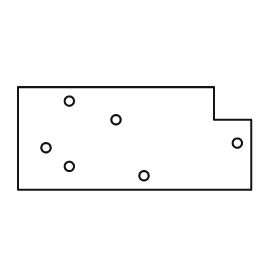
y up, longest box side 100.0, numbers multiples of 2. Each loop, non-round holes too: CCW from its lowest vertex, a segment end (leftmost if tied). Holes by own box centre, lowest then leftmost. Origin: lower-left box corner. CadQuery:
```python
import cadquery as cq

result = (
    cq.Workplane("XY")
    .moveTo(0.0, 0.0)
    .lineTo(100.0, 0.0)
    .lineTo(100.0, 30.0)
    .lineTo(84.0, 30.0)
    .lineTo(84.0, 44.0)
    .lineTo(0.0, 44.0)
    .close()
    .moveTo(54.0, 6.0)
    .circle(2.0)
    .moveTo(22.0, 10.0)
    .circle(2.0)
    .moveTo(12.0, 18.0)
    .circle(2.0)
    .moveTo(94.0, 20.0)
    .circle(2.0)
    .moveTo(42.0, 30.0)
    .circle(2.0)
    .moveTo(22.0, 38.0)
    .circle(2.0)
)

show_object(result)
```